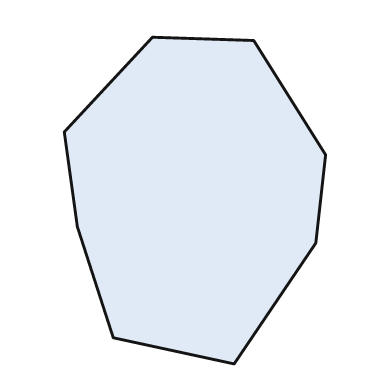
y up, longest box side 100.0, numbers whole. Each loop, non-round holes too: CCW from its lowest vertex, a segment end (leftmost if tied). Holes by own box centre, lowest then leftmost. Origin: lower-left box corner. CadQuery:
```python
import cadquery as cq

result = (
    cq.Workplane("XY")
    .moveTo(52.0, 0.0)
    .lineTo(77.0, 37.0)
    .lineTo(80.0, 64.0)
    .lineTo(58.0, 99.0)
    .lineTo(27.0, 100.0)
    .lineTo(0.0, 71.0)
    .lineTo(4.0, 42.0)
    .lineTo(15.0, 8.0)
    .close()
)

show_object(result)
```